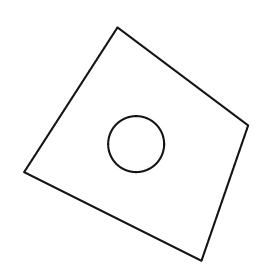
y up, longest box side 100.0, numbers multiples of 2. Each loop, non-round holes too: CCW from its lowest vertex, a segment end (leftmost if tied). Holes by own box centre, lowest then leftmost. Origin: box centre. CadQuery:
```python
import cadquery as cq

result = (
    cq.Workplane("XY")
    .moveTo(28.0, -50.0)
    .lineTo(48.0, 8.0)
    .lineTo(-8.0, 50.0)
    .lineTo(-48.0, -12.0)
    .close()
    .moveTo(0.0, 0.0)
    .circle(12.0)
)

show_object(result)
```